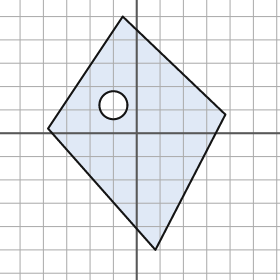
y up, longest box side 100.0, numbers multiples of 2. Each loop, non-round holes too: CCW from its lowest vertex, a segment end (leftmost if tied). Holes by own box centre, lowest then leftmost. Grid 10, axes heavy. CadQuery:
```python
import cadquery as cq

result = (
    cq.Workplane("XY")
    .moveTo(8.0, -50.0)
    .lineTo(38.0, 8.0)
    .lineTo(-6.0, 50.0)
    .lineTo(-38.0, 2.0)
    .close()
    .moveTo(-10.0, 12.0)
    .circle(6.0)
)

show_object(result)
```